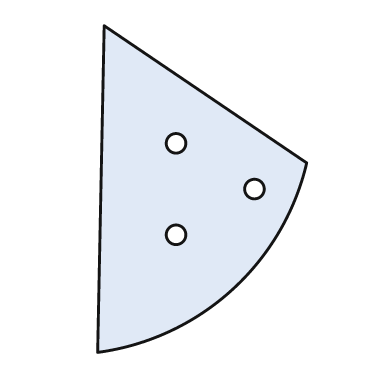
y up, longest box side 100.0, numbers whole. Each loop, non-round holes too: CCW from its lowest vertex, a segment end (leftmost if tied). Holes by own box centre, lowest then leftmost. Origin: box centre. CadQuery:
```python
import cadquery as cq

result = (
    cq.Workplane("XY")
    .moveTo(-32.0, -50.0)
    .threePointArc((9.0, -31.0), (32.0, 8.0))
    .lineTo(-30.0, 50.0)
    .close()
    .moveTo(-8.0, -14.0)
    .circle(3.0)
    .moveTo(16.0, 0.0)
    .circle(3.0)
    .moveTo(-8.0, 14.0)
    .circle(3.0)
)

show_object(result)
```